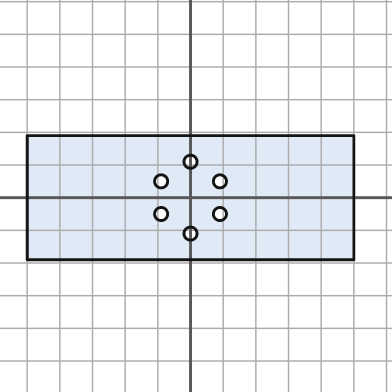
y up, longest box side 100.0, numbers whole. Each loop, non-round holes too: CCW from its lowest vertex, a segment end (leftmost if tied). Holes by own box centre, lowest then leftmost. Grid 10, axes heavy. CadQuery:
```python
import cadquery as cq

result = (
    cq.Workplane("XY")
    .moveTo(-50.0, -19.0)
    .lineTo(50.0, -19.0)
    .lineTo(50.0, 19.0)
    .lineTo(-50.0, 19.0)
    .close()
    .moveTo(0.0, -11.0)
    .circle(2.0)
    .moveTo(-9.0, -5.0)
    .circle(2.0)
    .moveTo(9.0, -5.0)
    .circle(2.0)
    .moveTo(-9.0, 5.0)
    .circle(2.0)
    .moveTo(9.0, 5.0)
    .circle(2.0)
    .moveTo(0.0, 11.0)
    .circle(2.0)
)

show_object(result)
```